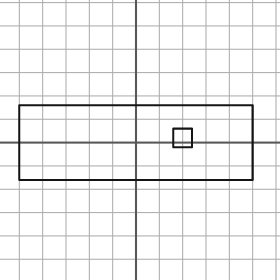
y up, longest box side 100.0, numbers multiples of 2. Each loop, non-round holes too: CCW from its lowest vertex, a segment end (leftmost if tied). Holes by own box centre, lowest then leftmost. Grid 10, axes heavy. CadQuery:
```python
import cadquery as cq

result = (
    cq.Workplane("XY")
    .moveTo(-50.0, -16.0)
    .lineTo(50.0, -16.0)
    .lineTo(50.0, 16.0)
    .lineTo(-50.0, 16.0)
    .close()
    .moveTo(16.0, -2.0)
    .lineTo(24.0, -2.0)
    .lineTo(24.0, 6.0)
    .lineTo(16.0, 6.0)
    .close()
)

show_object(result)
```